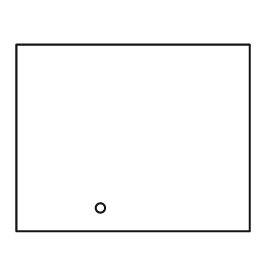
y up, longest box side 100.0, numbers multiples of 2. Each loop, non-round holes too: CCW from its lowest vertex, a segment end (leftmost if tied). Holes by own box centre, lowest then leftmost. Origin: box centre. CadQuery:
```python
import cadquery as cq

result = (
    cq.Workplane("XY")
    .moveTo(-50.0, -40.0)
    .lineTo(50.0, -40.0)
    .lineTo(50.0, 40.0)
    .lineTo(-50.0, 40.0)
    .close()
    .moveTo(-14.0, -30.0)
    .circle(2.0)
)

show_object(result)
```